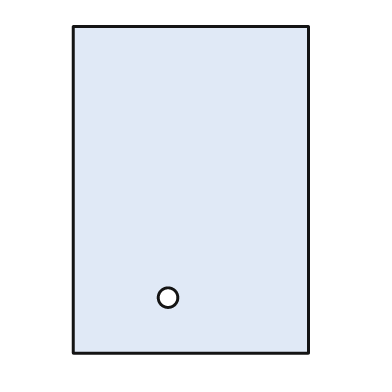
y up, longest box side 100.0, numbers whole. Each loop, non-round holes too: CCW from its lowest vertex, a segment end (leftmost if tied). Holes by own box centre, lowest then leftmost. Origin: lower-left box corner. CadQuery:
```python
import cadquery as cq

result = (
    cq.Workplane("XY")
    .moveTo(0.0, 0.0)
    .lineTo(72.0, 0.0)
    .lineTo(72.0, 100.0)
    .lineTo(0.0, 100.0)
    .close()
    .moveTo(29.0, 17.0)
    .circle(3.0)
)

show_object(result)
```